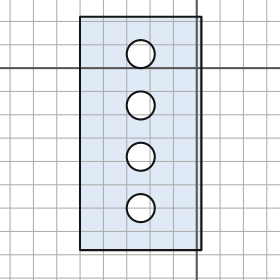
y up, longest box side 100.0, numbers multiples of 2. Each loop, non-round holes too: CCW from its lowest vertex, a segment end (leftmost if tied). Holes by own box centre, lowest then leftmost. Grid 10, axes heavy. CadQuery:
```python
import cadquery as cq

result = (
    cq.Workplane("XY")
    .moveTo(-50.0, -78.0)
    .lineTo(2.0, -78.0)
    .lineTo(2.0, 22.0)
    .lineTo(-50.0, 22.0)
    .close()
    .moveTo(-24.0, -60.0)
    .circle(6.0)
    .moveTo(-24.0, -38.0)
    .circle(6.0)
    .moveTo(-24.0, -16.0)
    .circle(6.0)
    .moveTo(-24.0, 6.0)
    .circle(6.0)
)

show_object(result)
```